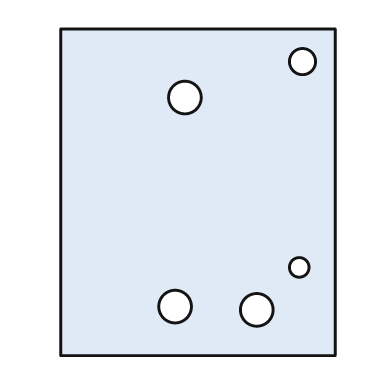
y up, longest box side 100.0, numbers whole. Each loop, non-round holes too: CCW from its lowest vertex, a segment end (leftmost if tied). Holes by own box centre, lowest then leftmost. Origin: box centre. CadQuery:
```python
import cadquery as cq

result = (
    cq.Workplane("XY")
    .moveTo(-42.0, -50.0)
    .lineTo(42.0, -50.0)
    .lineTo(42.0, 50.0)
    .lineTo(-42.0, 50.0)
    .close()
    .moveTo(18.0, -36.0)
    .circle(5.0)
    .moveTo(-7.0, -35.0)
    .circle(5.0)
    .moveTo(31.0, -23.0)
    .circle(3.0)
    .moveTo(-4.0, 29.0)
    .circle(5.0)
    .moveTo(32.0, 40.0)
    .circle(4.0)
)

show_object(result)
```